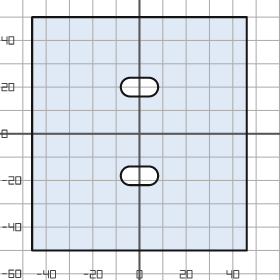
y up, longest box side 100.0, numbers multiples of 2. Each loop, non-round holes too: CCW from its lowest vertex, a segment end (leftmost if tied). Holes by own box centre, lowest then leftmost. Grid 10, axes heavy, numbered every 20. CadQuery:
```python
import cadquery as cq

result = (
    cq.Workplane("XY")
    .moveTo(-46.0, -50.0)
    .lineTo(46.0, -50.0)
    .lineTo(46.0, 50.0)
    .lineTo(-46.0, 50.0)
    .close()
    .moveTo(-4.0, -22.0)
    .lineTo(4.0, -22.0)
    .threePointArc((8.0, -18.0), (4.0, -14.0))
    .lineTo(-4.0, -14.0)
    .threePointArc((-8.0, -18.0), (-4.0, -22.0))
    .close()
    .moveTo(-4.0, 16.0)
    .lineTo(4.0, 16.0)
    .threePointArc((8.0, 20.0), (4.0, 24.0))
    .lineTo(-4.0, 24.0)
    .threePointArc((-8.0, 20.0), (-4.0, 16.0))
    .close()
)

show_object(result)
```